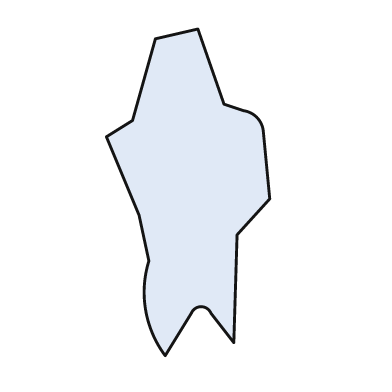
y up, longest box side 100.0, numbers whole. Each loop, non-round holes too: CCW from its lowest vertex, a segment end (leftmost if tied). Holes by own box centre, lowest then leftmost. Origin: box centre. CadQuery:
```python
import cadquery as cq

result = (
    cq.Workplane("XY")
    .moveTo(-7.0, -50.0)
    .lineTo(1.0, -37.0)
    .threePointArc((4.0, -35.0), (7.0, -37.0))
    .lineTo(14.0, -46.0)
    .lineTo(15.0, -13.0)
    .lineTo(25.0, -2.0)
    .lineTo(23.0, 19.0)
    .threePointArc((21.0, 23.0), (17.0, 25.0))
    .lineTo(11.0, 27.0)
    .lineTo(3.0, 50.0)
    .lineTo(-10.0, 47.0)
    .lineTo(-17.0, 22.0)
    .lineTo(-25.0, 17.0)
    .lineTo(-15.0, -7.0)
    .lineTo(-12.0, -21.0)
    .threePointArc((-13.0, -36.0), (-7.0, -50.0))
    .close()
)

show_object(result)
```